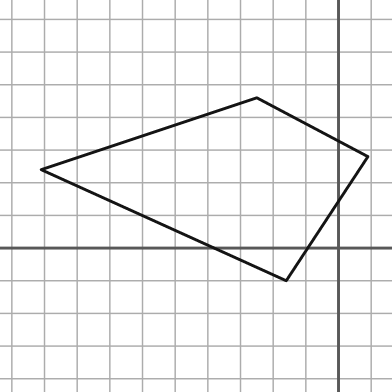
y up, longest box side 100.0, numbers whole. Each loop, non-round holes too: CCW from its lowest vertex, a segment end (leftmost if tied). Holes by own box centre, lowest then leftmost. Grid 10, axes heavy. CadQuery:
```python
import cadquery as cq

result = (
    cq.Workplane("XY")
    .moveTo(-16.0, -10.0)
    .lineTo(9.0, 28.0)
    .lineTo(-25.0, 46.0)
    .lineTo(-91.0, 24.0)
    .close()
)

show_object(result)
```